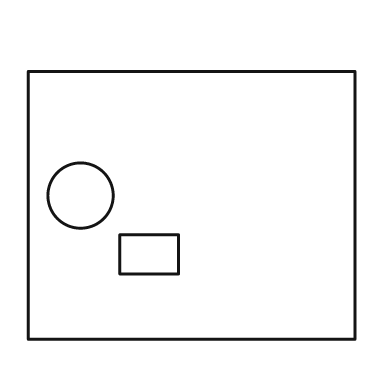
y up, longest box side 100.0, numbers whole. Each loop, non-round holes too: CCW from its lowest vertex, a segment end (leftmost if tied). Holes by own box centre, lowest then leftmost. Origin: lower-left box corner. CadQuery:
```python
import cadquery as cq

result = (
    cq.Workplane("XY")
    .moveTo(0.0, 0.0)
    .lineTo(100.0, 0.0)
    .lineTo(100.0, 82.0)
    .lineTo(0.0, 82.0)
    .close()
    .moveTo(28.0, 20.0)
    .lineTo(46.0, 20.0)
    .lineTo(46.0, 32.0)
    .lineTo(28.0, 32.0)
    .close()
    .moveTo(16.0, 44.0)
    .circle(10.0)
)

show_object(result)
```